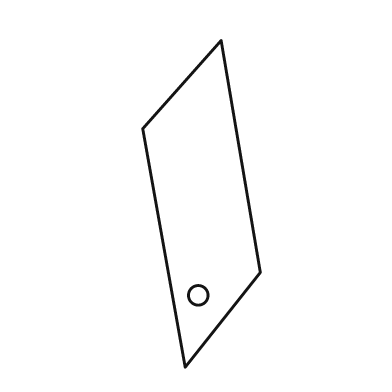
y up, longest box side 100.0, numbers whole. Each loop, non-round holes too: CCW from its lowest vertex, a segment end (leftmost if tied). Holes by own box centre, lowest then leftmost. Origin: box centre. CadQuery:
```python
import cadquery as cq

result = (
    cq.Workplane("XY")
    .moveTo(-5.0, -50.0)
    .lineTo(18.0, -21.0)
    .lineTo(6.0, 50.0)
    .lineTo(-18.0, 23.0)
    .close()
    .moveTo(-1.0, -28.0)
    .circle(3.0)
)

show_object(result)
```